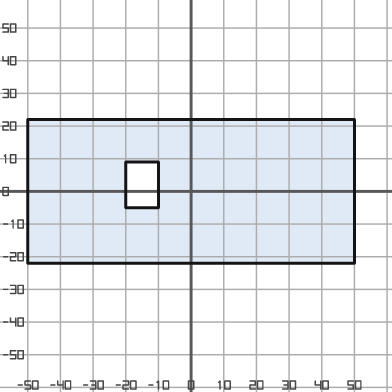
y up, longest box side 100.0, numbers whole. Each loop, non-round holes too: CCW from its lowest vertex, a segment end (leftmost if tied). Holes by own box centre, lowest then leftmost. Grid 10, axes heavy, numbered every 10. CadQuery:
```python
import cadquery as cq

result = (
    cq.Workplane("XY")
    .moveTo(-50.0, -22.0)
    .lineTo(50.0, -22.0)
    .lineTo(50.0, 22.0)
    .lineTo(-50.0, 22.0)
    .close()
    .moveTo(-20.0, -5.0)
    .lineTo(-10.0, -5.0)
    .lineTo(-10.0, 9.0)
    .lineTo(-20.0, 9.0)
    .close()
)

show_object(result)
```